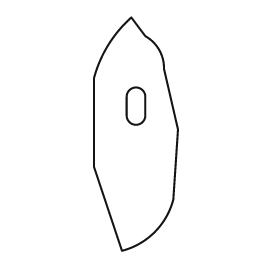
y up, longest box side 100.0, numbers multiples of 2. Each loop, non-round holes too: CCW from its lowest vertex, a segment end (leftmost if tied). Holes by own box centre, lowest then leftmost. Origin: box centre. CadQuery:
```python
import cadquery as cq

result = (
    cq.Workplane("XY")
    .moveTo(-6.0, -50.0)
    .threePointArc((8.0, -42.0), (16.0, -28.0))
    .lineTo(18.0, 2.0)
    .lineTo(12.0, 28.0)
    .threePointArc((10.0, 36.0), (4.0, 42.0))
    .lineTo(-2.0, 50.0)
    .threePointArc((-12.0, 38.0), (-18.0, 24.0))
    .lineTo(-18.0, -14.0)
    .close()
    .moveTo(-4.0, 8.0)
    .threePointArc((0.0, 4.0), (4.0, 8.0))
    .lineTo(4.0, 16.0)
    .threePointArc((0.0, 20.0), (-4.0, 16.0))
    .close()
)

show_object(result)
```